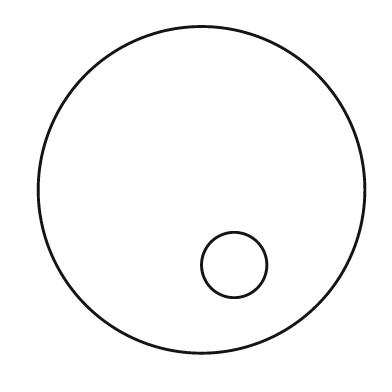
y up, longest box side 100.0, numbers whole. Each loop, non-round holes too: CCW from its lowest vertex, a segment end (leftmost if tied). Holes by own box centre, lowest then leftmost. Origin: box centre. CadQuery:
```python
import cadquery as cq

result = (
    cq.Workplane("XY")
    .moveTo(0.0, 0.0)
    .circle(50.0)
    .moveTo(10.0, -23.0)
    .circle(10.0)
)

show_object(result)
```